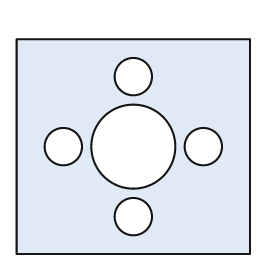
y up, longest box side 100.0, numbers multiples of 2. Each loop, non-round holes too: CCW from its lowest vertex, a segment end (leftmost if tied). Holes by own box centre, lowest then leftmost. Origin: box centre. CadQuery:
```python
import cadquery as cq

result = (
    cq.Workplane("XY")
    .moveTo(-50.0, -46.0)
    .lineTo(50.0, -46.0)
    .lineTo(50.0, 46.0)
    .lineTo(-50.0, 46.0)
    .close()
    .moveTo(0.0, -30.0)
    .circle(8.0)
    .moveTo(-30.0, 0.0)
    .circle(8.0)
    .moveTo(0.0, 0.0)
    .circle(18.0)
    .moveTo(30.0, 0.0)
    .circle(8.0)
    .moveTo(0.0, 30.0)
    .circle(8.0)
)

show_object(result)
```